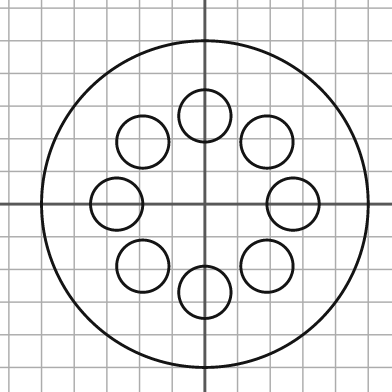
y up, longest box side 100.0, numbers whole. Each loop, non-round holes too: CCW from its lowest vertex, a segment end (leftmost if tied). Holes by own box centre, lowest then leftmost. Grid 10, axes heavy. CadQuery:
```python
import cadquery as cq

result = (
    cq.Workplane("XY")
    .moveTo(0.0, 0.0)
    .circle(50.0)
    .moveTo(0.0, -27.0)
    .circle(8.0)
    .moveTo(-19.0, -19.0)
    .circle(8.0)
    .moveTo(19.0, -19.0)
    .circle(8.0)
    .moveTo(-27.0, 0.0)
    .circle(8.0)
    .moveTo(27.0, 0.0)
    .circle(8.0)
    .moveTo(-19.0, 19.0)
    .circle(8.0)
    .moveTo(19.0, 19.0)
    .circle(8.0)
    .moveTo(0.0, 27.0)
    .circle(8.0)
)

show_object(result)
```